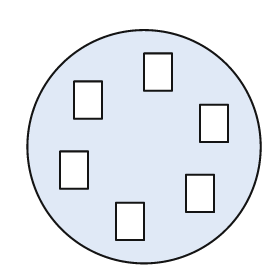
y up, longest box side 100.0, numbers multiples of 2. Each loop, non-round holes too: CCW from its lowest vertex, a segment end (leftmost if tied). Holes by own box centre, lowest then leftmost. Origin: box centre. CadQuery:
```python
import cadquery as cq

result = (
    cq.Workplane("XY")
    .moveTo(0.0, 0.0)
    .circle(50.0)
    .moveTo(-12.0, -40.0)
    .lineTo(0.0, -40.0)
    .lineTo(0.0, -24.0)
    .lineTo(-12.0, -24.0)
    .close()
    .moveTo(18.0, -28.0)
    .lineTo(30.0, -28.0)
    .lineTo(30.0, -12.0)
    .lineTo(18.0, -12.0)
    .close()
    .moveTo(-36.0, -18.0)
    .lineTo(-24.0, -18.0)
    .lineTo(-24.0, -2.0)
    .lineTo(-36.0, -2.0)
    .close()
    .moveTo(24.0, 2.0)
    .lineTo(36.0, 2.0)
    .lineTo(36.0, 18.0)
    .lineTo(24.0, 18.0)
    .close()
    .moveTo(-30.0, 12.0)
    .lineTo(-18.0, 12.0)
    .lineTo(-18.0, 28.0)
    .lineTo(-30.0, 28.0)
    .close()
    .moveTo(0.0, 24.0)
    .lineTo(12.0, 24.0)
    .lineTo(12.0, 40.0)
    .lineTo(0.0, 40.0)
    .close()
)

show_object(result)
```